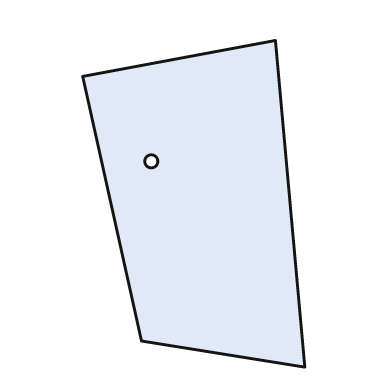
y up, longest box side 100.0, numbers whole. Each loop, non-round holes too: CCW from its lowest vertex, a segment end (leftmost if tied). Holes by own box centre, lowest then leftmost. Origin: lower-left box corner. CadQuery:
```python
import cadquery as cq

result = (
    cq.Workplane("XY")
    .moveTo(68.0, 0.0)
    .lineTo(59.0, 100.0)
    .lineTo(0.0, 89.0)
    .lineTo(18.0, 8.0)
    .close()
    .moveTo(21.0, 63.0)
    .circle(2.0)
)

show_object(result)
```